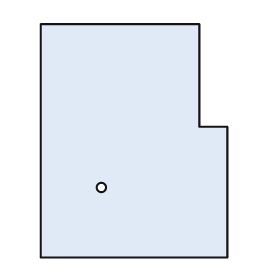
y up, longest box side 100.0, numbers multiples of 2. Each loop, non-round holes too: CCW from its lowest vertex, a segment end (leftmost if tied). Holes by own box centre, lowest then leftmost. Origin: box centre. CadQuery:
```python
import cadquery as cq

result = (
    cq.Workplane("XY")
    .moveTo(-40.0, -50.0)
    .lineTo(40.0, -50.0)
    .lineTo(40.0, 6.0)
    .lineTo(28.0, 6.0)
    .lineTo(28.0, 50.0)
    .lineTo(-40.0, 50.0)
    .close()
    .moveTo(-14.0, -20.0)
    .circle(2.0)
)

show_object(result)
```